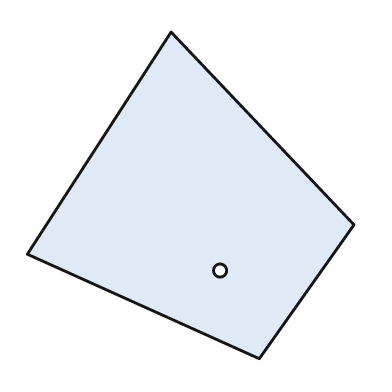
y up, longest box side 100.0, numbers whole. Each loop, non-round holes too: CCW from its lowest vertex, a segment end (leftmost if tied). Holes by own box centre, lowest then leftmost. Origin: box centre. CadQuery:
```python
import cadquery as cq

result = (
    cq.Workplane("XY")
    .moveTo(21.0, -50.0)
    .lineTo(50.0, -9.0)
    .lineTo(-6.0, 50.0)
    .lineTo(-50.0, -18.0)
    .close()
    .moveTo(9.0, -23.0)
    .circle(2.0)
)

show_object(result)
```